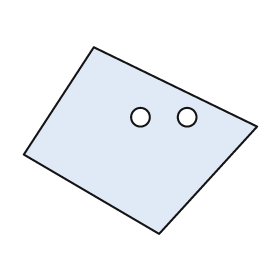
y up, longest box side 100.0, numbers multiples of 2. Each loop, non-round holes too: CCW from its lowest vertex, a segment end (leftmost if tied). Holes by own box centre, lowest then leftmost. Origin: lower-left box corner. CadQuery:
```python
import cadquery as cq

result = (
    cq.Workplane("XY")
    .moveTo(58.0, 0.0)
    .lineTo(100.0, 46.0)
    .lineTo(30.0, 80.0)
    .lineTo(0.0, 34.0)
    .close()
    .moveTo(50.0, 50.0)
    .circle(4.0)
    .moveTo(70.0, 50.0)
    .circle(4.0)
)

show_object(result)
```